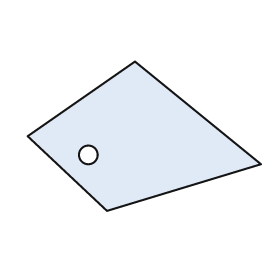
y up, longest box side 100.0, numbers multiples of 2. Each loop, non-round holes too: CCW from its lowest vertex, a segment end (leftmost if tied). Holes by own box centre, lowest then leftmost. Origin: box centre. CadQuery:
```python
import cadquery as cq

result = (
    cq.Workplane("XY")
    .moveTo(-16.0, -32.0)
    .lineTo(50.0, -12.0)
    .lineTo(-4.0, 32.0)
    .lineTo(-50.0, 0.0)
    .close()
    .moveTo(-24.0, -8.0)
    .circle(4.0)
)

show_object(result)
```